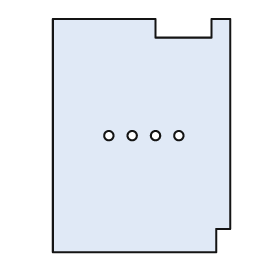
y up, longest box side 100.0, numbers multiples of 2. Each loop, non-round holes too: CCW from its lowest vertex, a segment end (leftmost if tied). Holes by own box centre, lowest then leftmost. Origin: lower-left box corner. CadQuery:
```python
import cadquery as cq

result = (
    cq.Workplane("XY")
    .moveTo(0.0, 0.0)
    .lineTo(70.0, 0.0)
    .lineTo(70.0, 10.0)
    .lineTo(76.0, 10.0)
    .lineTo(76.0, 100.0)
    .lineTo(68.0, 100.0)
    .lineTo(68.0, 92.0)
    .lineTo(44.0, 92.0)
    .lineTo(44.0, 100.0)
    .lineTo(0.0, 100.0)
    .close()
    .moveTo(24.0, 50.0)
    .circle(2.0)
    .moveTo(34.0, 50.0)
    .circle(2.0)
    .moveTo(44.0, 50.0)
    .circle(2.0)
    .moveTo(54.0, 50.0)
    .circle(2.0)
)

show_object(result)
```